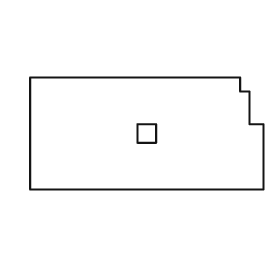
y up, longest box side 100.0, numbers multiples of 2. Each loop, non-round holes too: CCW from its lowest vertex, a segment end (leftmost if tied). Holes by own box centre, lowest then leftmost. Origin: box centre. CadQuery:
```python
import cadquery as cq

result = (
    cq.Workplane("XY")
    .moveTo(-50.0, -24.0)
    .lineTo(50.0, -24.0)
    .lineTo(50.0, 4.0)
    .lineTo(44.0, 4.0)
    .lineTo(44.0, 18.0)
    .lineTo(40.0, 18.0)
    .lineTo(40.0, 24.0)
    .lineTo(-50.0, 24.0)
    .close()
    .moveTo(-4.0, -4.0)
    .lineTo(4.0, -4.0)
    .lineTo(4.0, 4.0)
    .lineTo(-4.0, 4.0)
    .close()
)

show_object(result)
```